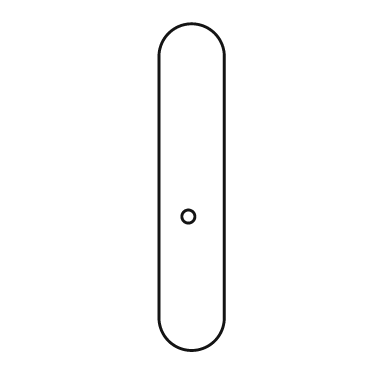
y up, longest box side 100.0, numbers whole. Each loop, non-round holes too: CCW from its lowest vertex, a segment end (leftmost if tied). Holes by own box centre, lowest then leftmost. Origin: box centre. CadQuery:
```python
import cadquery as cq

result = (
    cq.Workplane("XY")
    .moveTo(-10.0, -40.0)
    .threePointArc((0.0, -50.0), (10.0, -40.0))
    .lineTo(10.0, 40.0)
    .threePointArc((0.0, 50.0), (-10.0, 40.0))
    .close()
    .moveTo(-1.0, -9.0)
    .circle(2.0)
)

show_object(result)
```